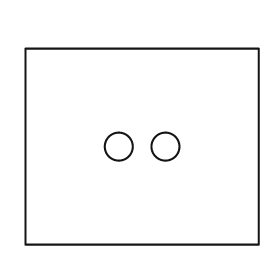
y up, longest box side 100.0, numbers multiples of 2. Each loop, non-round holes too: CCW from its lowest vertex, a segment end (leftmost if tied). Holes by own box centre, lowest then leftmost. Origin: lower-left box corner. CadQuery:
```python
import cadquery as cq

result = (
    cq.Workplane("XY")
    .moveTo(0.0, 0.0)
    .lineTo(100.0, 0.0)
    .lineTo(100.0, 84.0)
    .lineTo(0.0, 84.0)
    .close()
    .moveTo(40.0, 42.0)
    .circle(6.0)
    .moveTo(60.0, 42.0)
    .circle(6.0)
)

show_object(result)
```